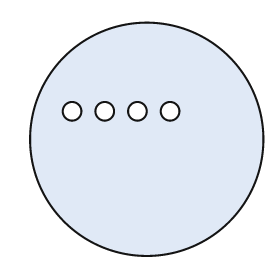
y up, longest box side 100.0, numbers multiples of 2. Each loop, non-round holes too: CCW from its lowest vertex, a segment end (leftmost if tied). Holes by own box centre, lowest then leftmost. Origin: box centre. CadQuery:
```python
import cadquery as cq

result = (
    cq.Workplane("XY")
    .moveTo(0.0, 0.0)
    .circle(50.0)
    .moveTo(-32.0, 12.0)
    .circle(4.0)
    .moveTo(-18.0, 12.0)
    .circle(4.0)
    .moveTo(-4.0, 12.0)
    .circle(4.0)
    .moveTo(10.0, 12.0)
    .circle(4.0)
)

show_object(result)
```